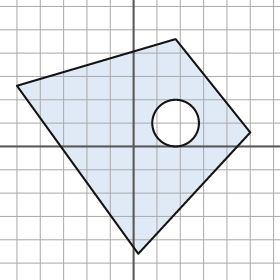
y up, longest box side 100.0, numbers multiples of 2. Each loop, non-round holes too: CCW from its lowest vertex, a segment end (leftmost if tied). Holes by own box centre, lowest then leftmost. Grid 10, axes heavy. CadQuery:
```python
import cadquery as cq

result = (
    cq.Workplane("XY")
    .moveTo(2.0, -46.0)
    .lineTo(50.0, 6.0)
    .lineTo(18.0, 46.0)
    .lineTo(-50.0, 26.0)
    .close()
    .moveTo(18.0, 10.0)
    .circle(10.0)
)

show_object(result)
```